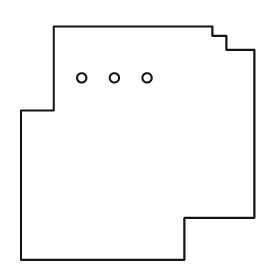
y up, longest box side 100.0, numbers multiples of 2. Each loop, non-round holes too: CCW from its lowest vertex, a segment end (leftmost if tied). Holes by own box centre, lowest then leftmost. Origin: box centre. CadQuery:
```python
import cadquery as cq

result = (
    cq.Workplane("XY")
    .moveTo(-50.0, -50.0)
    .lineTo(20.0, -50.0)
    .lineTo(20.0, -32.0)
    .lineTo(50.0, -32.0)
    .lineTo(50.0, 40.0)
    .lineTo(38.0, 40.0)
    .lineTo(38.0, 46.0)
    .lineTo(32.0, 46.0)
    .lineTo(32.0, 50.0)
    .lineTo(-36.0, 50.0)
    .lineTo(-36.0, 14.0)
    .lineTo(-50.0, 14.0)
    .close()
    .moveTo(-24.0, 28.0)
    .circle(2.0)
    .moveTo(-10.0, 28.0)
    .circle(2.0)
    .moveTo(4.0, 28.0)
    .circle(2.0)
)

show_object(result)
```